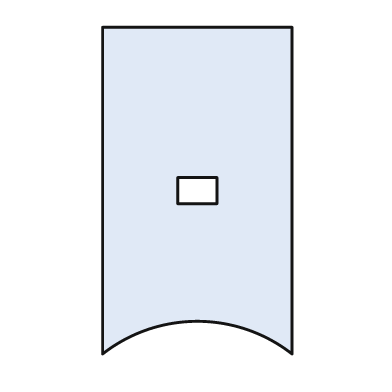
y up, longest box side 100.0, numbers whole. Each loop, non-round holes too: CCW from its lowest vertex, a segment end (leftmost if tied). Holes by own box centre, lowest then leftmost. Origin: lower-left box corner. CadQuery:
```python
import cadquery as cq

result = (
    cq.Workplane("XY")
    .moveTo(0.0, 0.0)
    .threePointArc((29.0, 10.0), (58.0, 0.0))
    .lineTo(58.0, 100.0)
    .lineTo(0.0, 100.0)
    .close()
    .moveTo(23.0, 46.0)
    .lineTo(35.0, 46.0)
    .lineTo(35.0, 54.0)
    .lineTo(23.0, 54.0)
    .close()
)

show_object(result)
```